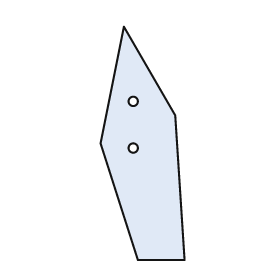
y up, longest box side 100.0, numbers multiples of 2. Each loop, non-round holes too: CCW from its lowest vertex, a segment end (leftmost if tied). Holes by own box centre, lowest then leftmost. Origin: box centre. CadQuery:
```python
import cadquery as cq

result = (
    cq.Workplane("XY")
    .moveTo(-2.0, -50.0)
    .lineTo(18.0, -50.0)
    .lineTo(14.0, 12.0)
    .lineTo(-8.0, 50.0)
    .lineTo(-18.0, 0.0)
    .close()
    .moveTo(-4.0, -2.0)
    .circle(2.0)
    .moveTo(-4.0, 18.0)
    .circle(2.0)
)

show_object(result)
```